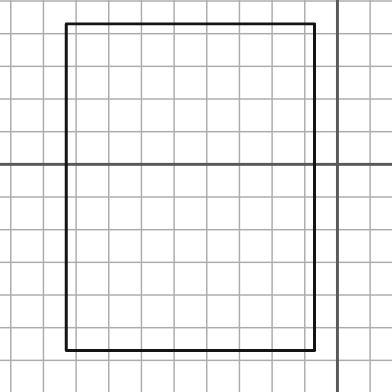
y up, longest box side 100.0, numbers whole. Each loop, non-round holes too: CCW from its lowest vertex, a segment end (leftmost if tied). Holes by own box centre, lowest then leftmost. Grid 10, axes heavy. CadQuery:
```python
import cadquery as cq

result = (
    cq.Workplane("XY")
    .moveTo(-83.0, -57.0)
    .lineTo(-7.0, -57.0)
    .lineTo(-7.0, 43.0)
    .lineTo(-83.0, 43.0)
    .close()
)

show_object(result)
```